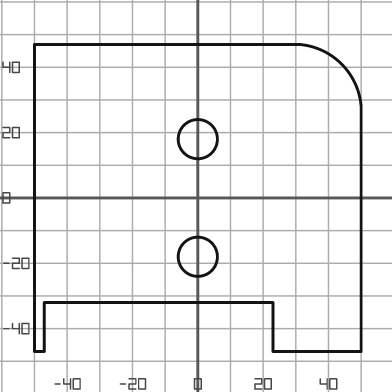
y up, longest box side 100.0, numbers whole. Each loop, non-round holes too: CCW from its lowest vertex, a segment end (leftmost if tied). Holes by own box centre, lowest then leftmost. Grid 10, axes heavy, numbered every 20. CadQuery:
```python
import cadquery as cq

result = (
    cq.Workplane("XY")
    .moveTo(-50.0, -47.0)
    .lineTo(-47.0, -47.0)
    .lineTo(-47.0, -32.0)
    .lineTo(23.0, -32.0)
    .lineTo(23.0, -47.0)
    .lineTo(50.0, -47.0)
    .lineTo(50.0, 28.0)
    .threePointArc((44.0, 41.0), (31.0, 47.0))
    .lineTo(-50.0, 47.0)
    .close()
    .moveTo(0.0, -18.0)
    .circle(6.0)
    .moveTo(0.0, 18.0)
    .circle(6.0)
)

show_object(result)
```